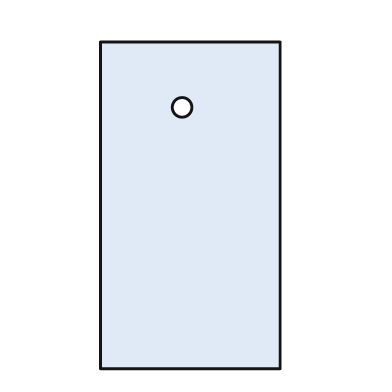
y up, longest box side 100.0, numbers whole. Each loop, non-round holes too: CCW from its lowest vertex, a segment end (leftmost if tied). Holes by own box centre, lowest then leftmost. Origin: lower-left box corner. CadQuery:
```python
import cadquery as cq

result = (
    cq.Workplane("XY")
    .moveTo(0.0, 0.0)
    .lineTo(55.0, 0.0)
    .lineTo(55.0, 100.0)
    .lineTo(0.0, 100.0)
    .close()
    .moveTo(25.0, 80.0)
    .circle(3.0)
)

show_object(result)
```